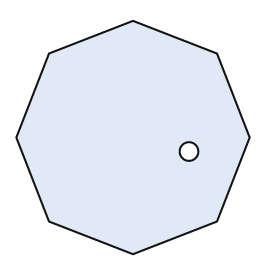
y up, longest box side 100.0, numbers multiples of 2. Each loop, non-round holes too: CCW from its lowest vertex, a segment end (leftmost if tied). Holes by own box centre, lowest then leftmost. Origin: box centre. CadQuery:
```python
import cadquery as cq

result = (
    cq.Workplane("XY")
    .moveTo(0.0, -50.0)
    .lineTo(36.0, -36.0)
    .lineTo(50.0, 0.0)
    .lineTo(36.0, 36.0)
    .lineTo(0.0, 50.0)
    .lineTo(-36.0, 36.0)
    .lineTo(-50.0, 0.0)
    .lineTo(-36.0, -36.0)
    .close()
    .moveTo(24.0, -6.0)
    .circle(4.0)
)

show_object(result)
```